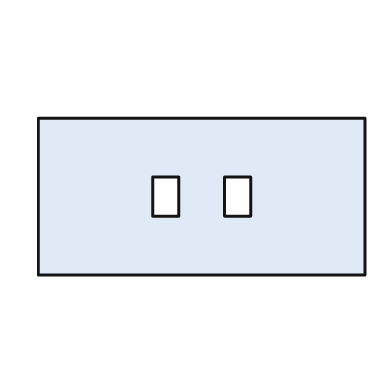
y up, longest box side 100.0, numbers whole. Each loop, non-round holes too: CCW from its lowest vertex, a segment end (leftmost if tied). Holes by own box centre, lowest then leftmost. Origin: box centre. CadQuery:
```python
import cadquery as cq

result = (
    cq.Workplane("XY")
    .moveTo(-50.0, -24.0)
    .lineTo(50.0, -24.0)
    .lineTo(50.0, 24.0)
    .lineTo(-50.0, 24.0)
    .close()
    .moveTo(-15.0, -6.0)
    .lineTo(-7.0, -6.0)
    .lineTo(-7.0, 6.0)
    .lineTo(-15.0, 6.0)
    .close()
    .moveTo(7.0, -6.0)
    .lineTo(15.0, -6.0)
    .lineTo(15.0, 6.0)
    .lineTo(7.0, 6.0)
    .close()
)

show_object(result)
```